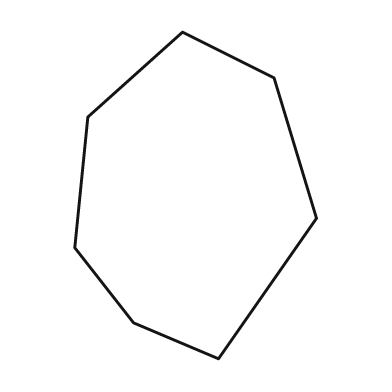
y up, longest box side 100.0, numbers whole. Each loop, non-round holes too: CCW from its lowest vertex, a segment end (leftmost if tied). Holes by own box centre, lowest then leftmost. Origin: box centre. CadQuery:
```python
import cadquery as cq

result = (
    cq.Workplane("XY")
    .moveTo(7.0, -50.0)
    .lineTo(37.0, -7.0)
    .lineTo(24.0, 36.0)
    .lineTo(-4.0, 50.0)
    .lineTo(-33.0, 24.0)
    .lineTo(-37.0, -16.0)
    .lineTo(-19.0, -39.0)
    .close()
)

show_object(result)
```